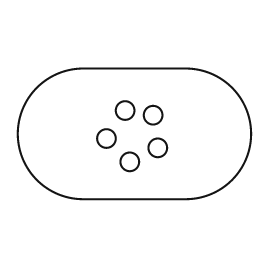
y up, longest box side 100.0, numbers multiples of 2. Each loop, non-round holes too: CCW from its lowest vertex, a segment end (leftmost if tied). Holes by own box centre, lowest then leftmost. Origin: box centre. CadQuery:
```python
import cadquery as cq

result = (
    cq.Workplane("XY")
    .moveTo(-22.0, -28.0)
    .lineTo(22.0, -28.0)
    .threePointArc((50.0, 0.0), (22.0, 28.0))
    .lineTo(-22.0, 28.0)
    .threePointArc((-50.0, 0.0), (-22.0, -28.0))
    .close()
    .moveTo(-2.0, -12.0)
    .circle(4.0)
    .moveTo(10.0, -6.0)
    .circle(4.0)
    .moveTo(-12.0, -2.0)
    .circle(4.0)
    .moveTo(8.0, 8.0)
    .circle(4.0)
    .moveTo(-4.0, 10.0)
    .circle(4.0)
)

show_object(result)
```